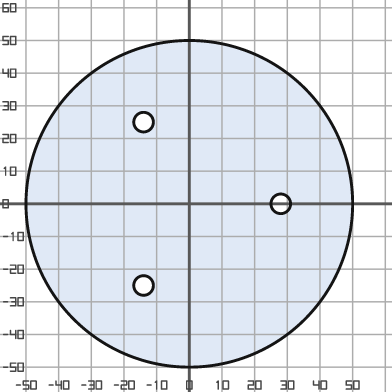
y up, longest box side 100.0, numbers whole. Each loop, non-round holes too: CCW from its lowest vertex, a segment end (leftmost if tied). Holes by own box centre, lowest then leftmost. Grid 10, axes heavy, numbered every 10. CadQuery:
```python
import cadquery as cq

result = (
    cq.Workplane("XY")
    .moveTo(0.0, 0.0)
    .circle(50.0)
    .moveTo(-14.0, -25.0)
    .circle(3.0)
    .moveTo(28.0, 0.0)
    .circle(3.0)
    .moveTo(-14.0, 25.0)
    .circle(3.0)
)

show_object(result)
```